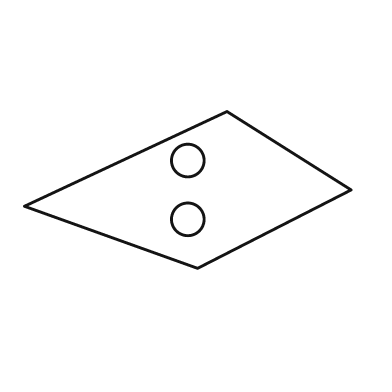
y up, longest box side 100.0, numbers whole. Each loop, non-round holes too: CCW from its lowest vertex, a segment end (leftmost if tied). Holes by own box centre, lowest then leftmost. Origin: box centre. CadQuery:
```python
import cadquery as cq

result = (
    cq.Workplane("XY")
    .moveTo(3.0, -24.0)
    .lineTo(50.0, 0.0)
    .lineTo(12.0, 24.0)
    .lineTo(-50.0, -5.0)
    .close()
    .moveTo(0.0, -9.0)
    .circle(5.0)
    .moveTo(0.0, 9.0)
    .circle(5.0)
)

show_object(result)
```